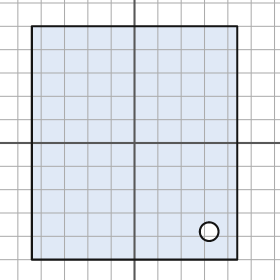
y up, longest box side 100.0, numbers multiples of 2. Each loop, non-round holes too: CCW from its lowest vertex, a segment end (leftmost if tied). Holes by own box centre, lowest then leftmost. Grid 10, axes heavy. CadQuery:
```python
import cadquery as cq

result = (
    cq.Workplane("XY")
    .moveTo(-44.0, -50.0)
    .lineTo(44.0, -50.0)
    .lineTo(44.0, 50.0)
    .lineTo(-44.0, 50.0)
    .close()
    .moveTo(32.0, -38.0)
    .circle(4.0)
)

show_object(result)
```